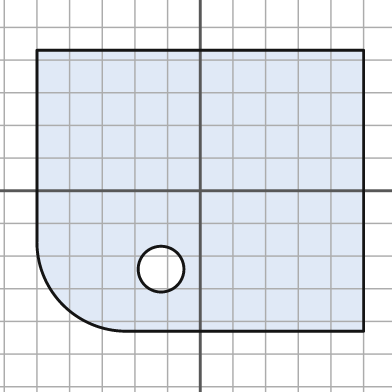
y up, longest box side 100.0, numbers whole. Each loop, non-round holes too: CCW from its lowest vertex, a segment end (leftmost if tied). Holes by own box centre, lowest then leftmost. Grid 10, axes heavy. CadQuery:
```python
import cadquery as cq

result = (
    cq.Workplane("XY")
    .moveTo(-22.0, -43.0)
    .lineTo(50.0, -43.0)
    .lineTo(50.0, 43.0)
    .lineTo(-50.0, 43.0)
    .lineTo(-50.0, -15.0)
    .threePointArc((-42.0, -35.0), (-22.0, -43.0))
    .close()
    .moveTo(-12.0, -24.0)
    .circle(7.0)
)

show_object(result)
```